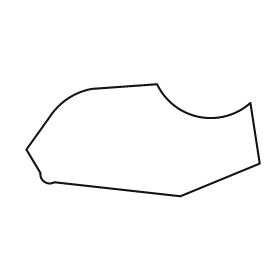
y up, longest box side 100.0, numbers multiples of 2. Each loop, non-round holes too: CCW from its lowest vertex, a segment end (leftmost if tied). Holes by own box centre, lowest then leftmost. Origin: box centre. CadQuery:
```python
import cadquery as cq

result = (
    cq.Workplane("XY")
    .moveTo(16.0, -24.0)
    .lineTo(50.0, -10.0)
    .lineTo(46.0, 16.0)
    .threePointArc((24.0, 10.0), (6.0, 24.0))
    .lineTo(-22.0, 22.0)
    .threePointArc((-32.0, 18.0), (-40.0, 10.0))
    .lineTo(-50.0, -4.0)
    .lineTo(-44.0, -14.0)
    .threePointArc((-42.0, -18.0), (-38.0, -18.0))
    .close()
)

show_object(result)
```